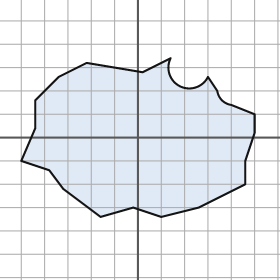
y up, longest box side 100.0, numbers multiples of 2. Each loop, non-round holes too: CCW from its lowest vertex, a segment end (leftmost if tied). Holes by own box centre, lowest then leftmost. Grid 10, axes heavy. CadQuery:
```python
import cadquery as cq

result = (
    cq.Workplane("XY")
    .moveTo(-16.0, -34.0)
    .lineTo(-2.0, -30.0)
    .lineTo(10.0, -34.0)
    .lineTo(26.0, -30.0)
    .lineTo(46.0, -20.0)
    .lineTo(46.0, -10.0)
    .lineTo(50.0, 2.0)
    .lineTo(50.0, 10.0)
    .lineTo(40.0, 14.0)
    .threePointArc((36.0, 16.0), (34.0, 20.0))
    .lineTo(30.0, 26.0)
    .threePointArc((18.0, 22.0), (14.0, 34.0))
    .lineTo(2.0, 28.0)
    .lineTo(-22.0, 32.0)
    .lineTo(-34.0, 26.0)
    .lineTo(-44.0, 16.0)
    .lineTo(-44.0, 4.0)
    .lineTo(-50.0, -10.0)
    .lineTo(-38.0, -14.0)
    .lineTo(-32.0, -22.0)
    .close()
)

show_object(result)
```